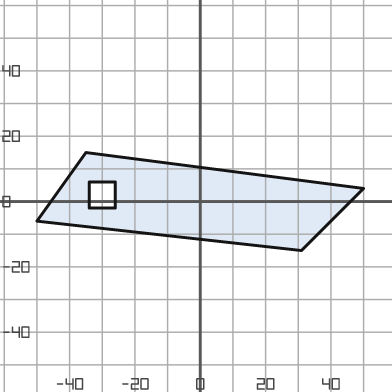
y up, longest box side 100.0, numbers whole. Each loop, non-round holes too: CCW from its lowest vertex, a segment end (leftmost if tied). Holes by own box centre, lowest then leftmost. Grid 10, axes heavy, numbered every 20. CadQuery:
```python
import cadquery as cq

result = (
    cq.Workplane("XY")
    .moveTo(31.0, -15.0)
    .lineTo(50.0, 4.0)
    .lineTo(-35.0, 15.0)
    .lineTo(-50.0, -6.0)
    .close()
    .moveTo(-34.0, -2.0)
    .lineTo(-26.0, -2.0)
    .lineTo(-26.0, 6.0)
    .lineTo(-34.0, 6.0)
    .close()
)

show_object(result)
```